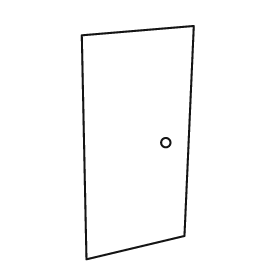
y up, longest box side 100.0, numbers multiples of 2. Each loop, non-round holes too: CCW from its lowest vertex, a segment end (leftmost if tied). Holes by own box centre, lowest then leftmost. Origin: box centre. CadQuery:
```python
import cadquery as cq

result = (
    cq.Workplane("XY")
    .moveTo(-22.0, -50.0)
    .lineTo(20.0, -40.0)
    .lineTo(24.0, 50.0)
    .lineTo(-24.0, 46.0)
    .close()
    .moveTo(12.0, 0.0)
    .circle(2.0)
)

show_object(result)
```